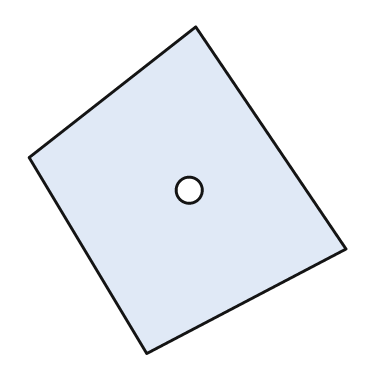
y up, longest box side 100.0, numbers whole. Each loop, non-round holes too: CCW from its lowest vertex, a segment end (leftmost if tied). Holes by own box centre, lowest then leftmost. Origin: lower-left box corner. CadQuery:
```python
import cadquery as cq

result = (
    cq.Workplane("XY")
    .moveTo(36.0, 0.0)
    .lineTo(97.0, 32.0)
    .lineTo(51.0, 100.0)
    .lineTo(0.0, 60.0)
    .close()
    .moveTo(49.0, 50.0)
    .circle(4.0)
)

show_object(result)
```